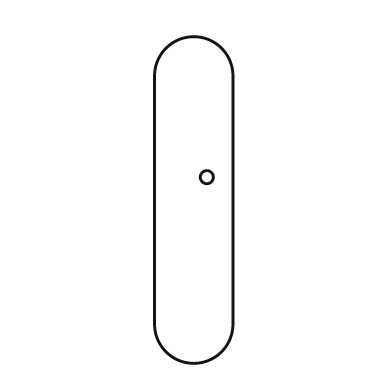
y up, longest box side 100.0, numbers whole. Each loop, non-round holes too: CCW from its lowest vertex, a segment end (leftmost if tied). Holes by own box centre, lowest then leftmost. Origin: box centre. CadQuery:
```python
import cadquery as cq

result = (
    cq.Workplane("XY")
    .moveTo(-12.0, -38.0)
    .threePointArc((0.0, -50.0), (12.0, -38.0))
    .lineTo(12.0, 38.0)
    .threePointArc((0.0, 50.0), (-12.0, 38.0))
    .close()
    .moveTo(4.0, 7.0)
    .circle(2.0)
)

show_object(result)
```